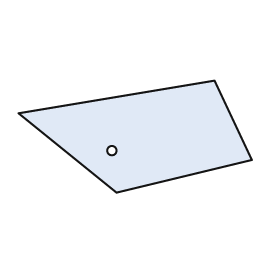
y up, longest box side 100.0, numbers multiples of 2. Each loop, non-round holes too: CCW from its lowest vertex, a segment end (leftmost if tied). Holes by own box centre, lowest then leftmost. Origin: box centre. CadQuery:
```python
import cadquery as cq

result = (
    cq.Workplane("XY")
    .moveTo(-8.0, -24.0)
    .lineTo(50.0, -10.0)
    .lineTo(34.0, 24.0)
    .lineTo(-50.0, 10.0)
    .close()
    .moveTo(-10.0, -6.0)
    .circle(2.0)
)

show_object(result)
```